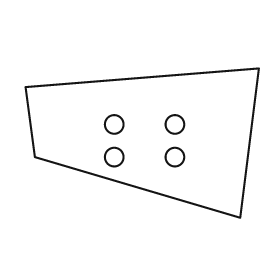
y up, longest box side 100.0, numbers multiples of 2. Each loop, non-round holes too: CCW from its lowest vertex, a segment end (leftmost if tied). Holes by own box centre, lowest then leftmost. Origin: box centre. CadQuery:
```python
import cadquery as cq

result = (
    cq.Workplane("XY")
    .moveTo(42.0, -32.0)
    .lineTo(50.0, 32.0)
    .lineTo(-50.0, 24.0)
    .lineTo(-46.0, -6.0)
    .close()
    .moveTo(-12.0, -6.0)
    .circle(4.0)
    .moveTo(14.0, -6.0)
    .circle(4.0)
    .moveTo(-12.0, 8.0)
    .circle(4.0)
    .moveTo(14.0, 8.0)
    .circle(4.0)
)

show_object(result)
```